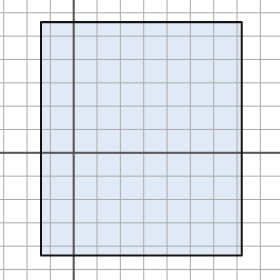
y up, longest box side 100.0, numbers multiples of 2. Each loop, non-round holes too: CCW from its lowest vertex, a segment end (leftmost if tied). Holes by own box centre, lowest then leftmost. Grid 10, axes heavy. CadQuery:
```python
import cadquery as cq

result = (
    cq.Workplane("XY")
    .moveTo(-14.0, -44.0)
    .lineTo(72.0, -44.0)
    .lineTo(72.0, 56.0)
    .lineTo(-14.0, 56.0)
    .close()
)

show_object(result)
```